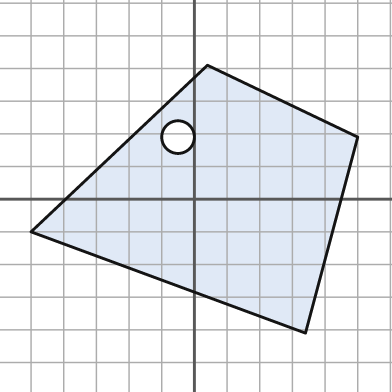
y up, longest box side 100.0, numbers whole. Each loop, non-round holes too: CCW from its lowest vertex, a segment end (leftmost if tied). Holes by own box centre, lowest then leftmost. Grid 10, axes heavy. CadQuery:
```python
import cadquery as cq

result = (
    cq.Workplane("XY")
    .moveTo(34.0, -41.0)
    .lineTo(50.0, 19.0)
    .lineTo(4.0, 41.0)
    .lineTo(-50.0, -10.0)
    .close()
    .moveTo(-5.0, 19.0)
    .circle(5.0)
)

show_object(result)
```